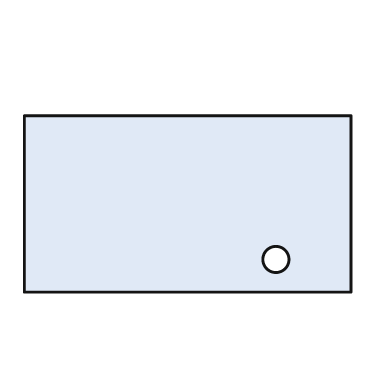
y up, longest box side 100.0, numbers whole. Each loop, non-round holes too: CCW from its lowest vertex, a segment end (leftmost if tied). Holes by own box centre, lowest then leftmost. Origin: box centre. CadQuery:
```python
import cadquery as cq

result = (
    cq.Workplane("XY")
    .moveTo(-50.0, -27.0)
    .lineTo(50.0, -27.0)
    .lineTo(50.0, 27.0)
    .lineTo(-50.0, 27.0)
    .close()
    .moveTo(27.0, -17.0)
    .circle(4.0)
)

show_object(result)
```